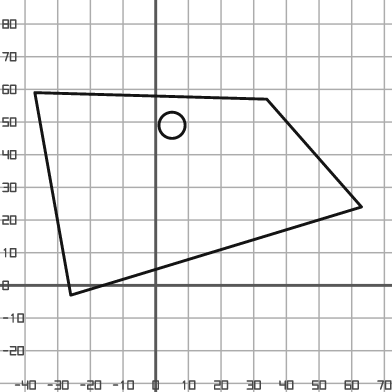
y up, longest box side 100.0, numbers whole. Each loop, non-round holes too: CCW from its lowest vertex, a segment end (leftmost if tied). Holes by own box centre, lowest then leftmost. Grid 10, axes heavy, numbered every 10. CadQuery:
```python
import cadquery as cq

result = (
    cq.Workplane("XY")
    .moveTo(-26.0, -3.0)
    .lineTo(63.0, 24.0)
    .lineTo(34.0, 57.0)
    .lineTo(-37.0, 59.0)
    .close()
    .moveTo(5.0, 49.0)
    .circle(4.0)
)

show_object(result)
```